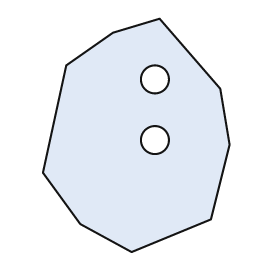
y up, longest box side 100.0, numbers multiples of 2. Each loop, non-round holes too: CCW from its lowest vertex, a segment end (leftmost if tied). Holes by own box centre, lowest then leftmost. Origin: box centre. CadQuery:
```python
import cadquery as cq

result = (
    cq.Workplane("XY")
    .moveTo(-2.0, -50.0)
    .lineTo(32.0, -36.0)
    .lineTo(40.0, -4.0)
    .lineTo(36.0, 20.0)
    .lineTo(10.0, 50.0)
    .lineTo(-10.0, 44.0)
    .lineTo(-30.0, 30.0)
    .lineTo(-40.0, -16.0)
    .lineTo(-24.0, -38.0)
    .close()
    .moveTo(8.0, -2.0)
    .circle(6.0)
    .moveTo(8.0, 24.0)
    .circle(6.0)
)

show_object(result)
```